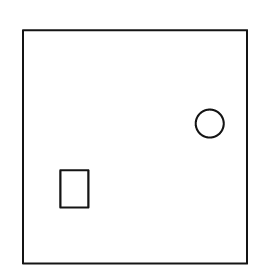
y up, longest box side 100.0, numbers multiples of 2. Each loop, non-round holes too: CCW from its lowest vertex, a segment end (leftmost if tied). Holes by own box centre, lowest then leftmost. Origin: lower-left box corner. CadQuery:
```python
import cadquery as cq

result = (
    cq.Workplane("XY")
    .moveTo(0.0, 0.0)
    .lineTo(96.0, 0.0)
    .lineTo(96.0, 100.0)
    .lineTo(0.0, 100.0)
    .close()
    .moveTo(16.0, 24.0)
    .lineTo(28.0, 24.0)
    .lineTo(28.0, 40.0)
    .lineTo(16.0, 40.0)
    .close()
    .moveTo(80.0, 60.0)
    .circle(6.0)
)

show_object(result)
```